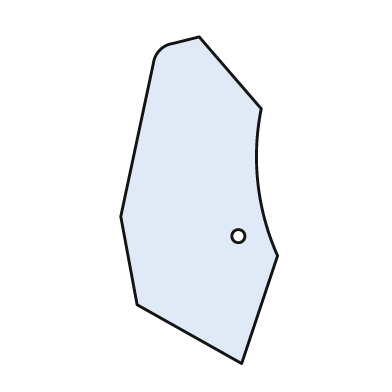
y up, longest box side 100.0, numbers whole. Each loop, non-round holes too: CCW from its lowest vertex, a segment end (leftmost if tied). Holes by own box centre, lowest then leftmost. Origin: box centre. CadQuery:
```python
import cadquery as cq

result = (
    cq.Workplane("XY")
    .moveTo(13.0, -50.0)
    .lineTo(24.0, -17.0)
    .threePointArc((18.0, 5.0), (19.0, 28.0))
    .lineTo(0.0, 50.0)
    .lineTo(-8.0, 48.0)
    .threePointArc((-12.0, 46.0), (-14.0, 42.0))
    .lineTo(-24.0, -5.0)
    .lineTo(-19.0, -32.0)
    .close()
    .moveTo(12.0, -11.0)
    .circle(2.0)
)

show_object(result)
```